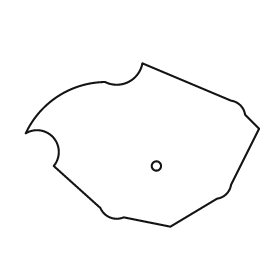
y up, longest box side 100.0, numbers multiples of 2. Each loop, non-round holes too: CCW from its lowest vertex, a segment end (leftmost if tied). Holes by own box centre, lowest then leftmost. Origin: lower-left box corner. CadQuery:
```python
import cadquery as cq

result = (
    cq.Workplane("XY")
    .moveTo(62.0, 0.0)
    .lineTo(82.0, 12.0)
    .threePointArc((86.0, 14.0), (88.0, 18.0))
    .lineTo(100.0, 42.0)
    .lineTo(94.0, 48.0)
    .threePointArc((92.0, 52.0), (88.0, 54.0))
    .lineTo(50.0, 70.0)
    .threePointArc((44.0, 62.0), (34.0, 62.0))
    .threePointArc((14.0, 56.0), (0.0, 40.0))
    .threePointArc((12.0, 38.0), (12.0, 26.0))
    .lineTo(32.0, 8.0)
    .threePointArc((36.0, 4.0), (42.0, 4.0))
    .close()
    .moveTo(56.0, 26.0)
    .circle(2.0)
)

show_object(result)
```